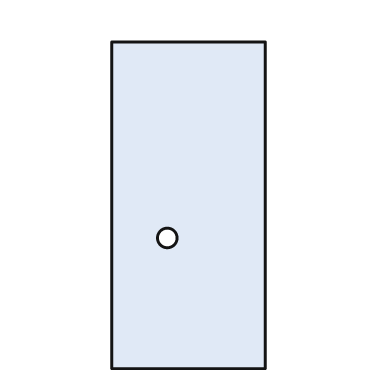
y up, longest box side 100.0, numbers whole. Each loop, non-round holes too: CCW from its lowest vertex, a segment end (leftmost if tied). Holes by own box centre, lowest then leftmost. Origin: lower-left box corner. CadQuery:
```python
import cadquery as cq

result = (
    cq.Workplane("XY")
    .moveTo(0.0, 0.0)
    .lineTo(47.0, 0.0)
    .lineTo(47.0, 100.0)
    .lineTo(0.0, 100.0)
    .close()
    .moveTo(17.0, 40.0)
    .circle(3.0)
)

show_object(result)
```